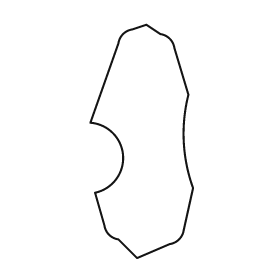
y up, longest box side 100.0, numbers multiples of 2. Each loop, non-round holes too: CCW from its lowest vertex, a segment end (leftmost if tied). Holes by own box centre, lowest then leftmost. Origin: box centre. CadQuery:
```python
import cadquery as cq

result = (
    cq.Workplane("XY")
    .moveTo(-2.0, -50.0)
    .lineTo(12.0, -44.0)
    .threePointArc((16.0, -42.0), (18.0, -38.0))
    .lineTo(22.0, -20.0)
    .threePointArc((18.0, 0.0), (20.0, 20.0))
    .lineTo(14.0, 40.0)
    .threePointArc((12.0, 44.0), (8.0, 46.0))
    .lineTo(2.0, 50.0)
    .lineTo(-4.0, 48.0)
    .threePointArc((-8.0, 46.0), (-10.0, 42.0))
    .lineTo(-22.0, 8.0)
    .threePointArc((-8.0, -6.0), (-20.0, -22.0))
    .lineTo(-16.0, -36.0)
    .threePointArc((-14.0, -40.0), (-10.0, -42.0))
    .close()
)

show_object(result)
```